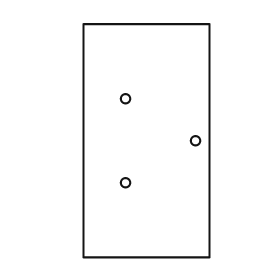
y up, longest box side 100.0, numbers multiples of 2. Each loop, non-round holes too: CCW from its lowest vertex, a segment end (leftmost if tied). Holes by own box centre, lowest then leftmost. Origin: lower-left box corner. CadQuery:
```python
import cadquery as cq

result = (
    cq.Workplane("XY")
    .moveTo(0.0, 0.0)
    .lineTo(54.0, 0.0)
    .lineTo(54.0, 100.0)
    .lineTo(0.0, 100.0)
    .close()
    .moveTo(18.0, 32.0)
    .circle(2.0)
    .moveTo(48.0, 50.0)
    .circle(2.0)
    .moveTo(18.0, 68.0)
    .circle(2.0)
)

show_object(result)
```